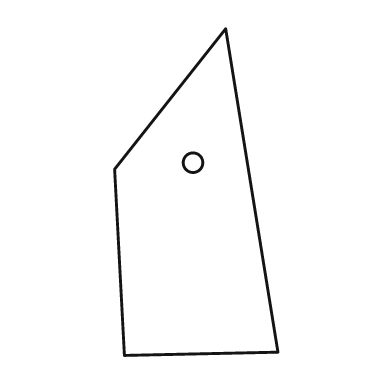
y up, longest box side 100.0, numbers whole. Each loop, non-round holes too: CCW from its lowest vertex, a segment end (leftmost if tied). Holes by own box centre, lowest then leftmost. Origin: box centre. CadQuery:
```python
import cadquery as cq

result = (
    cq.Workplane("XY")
    .moveTo(-22.0, -50.0)
    .lineTo(25.0, -49.0)
    .lineTo(9.0, 50.0)
    .lineTo(-25.0, 7.0)
    .close()
    .moveTo(-1.0, 9.0)
    .circle(3.0)
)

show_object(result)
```